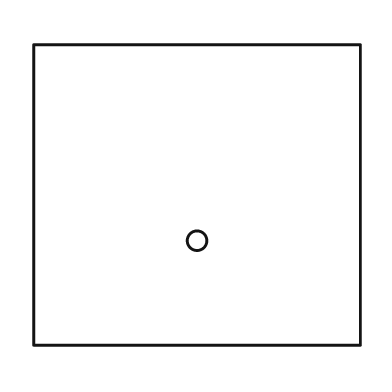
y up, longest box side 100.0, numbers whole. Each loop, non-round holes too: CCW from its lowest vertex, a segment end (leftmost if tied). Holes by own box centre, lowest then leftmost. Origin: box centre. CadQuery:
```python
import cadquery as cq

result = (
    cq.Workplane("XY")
    .moveTo(-50.0, -46.0)
    .lineTo(50.0, -46.0)
    .lineTo(50.0, 46.0)
    .lineTo(-50.0, 46.0)
    .close()
    .moveTo(0.0, -14.0)
    .circle(3.0)
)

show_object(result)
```